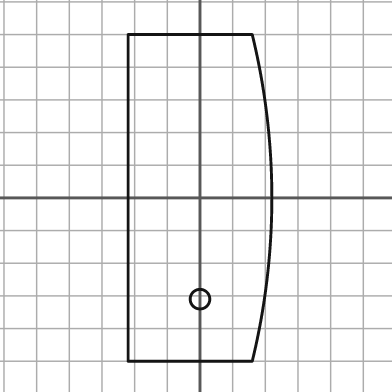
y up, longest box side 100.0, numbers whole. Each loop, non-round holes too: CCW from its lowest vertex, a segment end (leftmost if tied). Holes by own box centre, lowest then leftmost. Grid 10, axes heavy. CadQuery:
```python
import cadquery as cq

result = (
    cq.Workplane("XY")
    .moveTo(-22.0, -50.0)
    .lineTo(16.0, -50.0)
    .threePointArc((22.0, 0.0), (16.0, 50.0))
    .lineTo(-22.0, 50.0)
    .close()
    .moveTo(0.0, -31.0)
    .circle(3.0)
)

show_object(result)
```